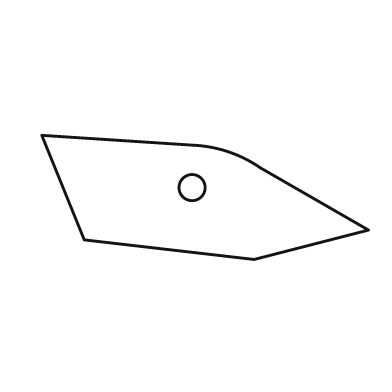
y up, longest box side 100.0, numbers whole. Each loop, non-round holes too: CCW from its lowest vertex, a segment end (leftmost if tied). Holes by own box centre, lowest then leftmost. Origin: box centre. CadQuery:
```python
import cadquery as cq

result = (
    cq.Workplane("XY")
    .moveTo(15.0, -19.0)
    .lineTo(50.0, -10.0)
    .lineTo(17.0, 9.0)
    .threePointArc((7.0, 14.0), (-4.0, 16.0))
    .lineTo(-50.0, 19.0)
    .lineTo(-37.0, -13.0)
    .close()
    .moveTo(-4.0, 3.0)
    .circle(4.0)
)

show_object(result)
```